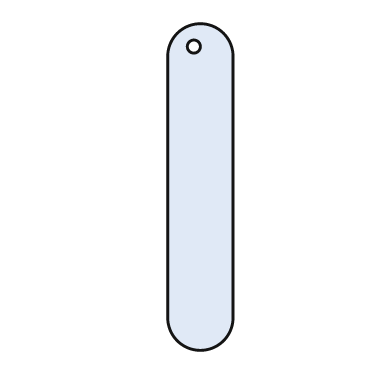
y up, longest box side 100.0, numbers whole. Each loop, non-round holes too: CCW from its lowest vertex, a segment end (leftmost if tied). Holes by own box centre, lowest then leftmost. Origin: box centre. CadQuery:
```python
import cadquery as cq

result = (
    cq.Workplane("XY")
    .moveTo(-10.0, -40.0)
    .threePointArc((0.0, -50.0), (10.0, -40.0))
    .lineTo(10.0, 40.0)
    .threePointArc((0.0, 50.0), (-10.0, 40.0))
    .close()
    .moveTo(-2.0, 43.0)
    .circle(2.0)
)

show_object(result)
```